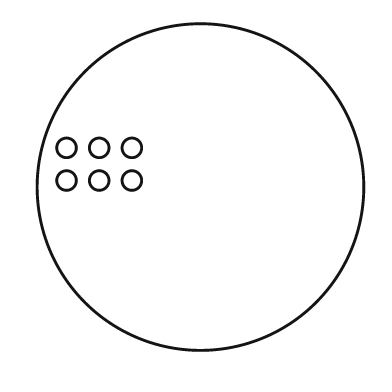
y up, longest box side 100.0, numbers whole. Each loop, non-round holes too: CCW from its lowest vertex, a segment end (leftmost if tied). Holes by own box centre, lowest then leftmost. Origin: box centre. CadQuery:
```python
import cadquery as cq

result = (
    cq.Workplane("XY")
    .moveTo(0.0, 0.0)
    .circle(50.0)
    .moveTo(-41.0, 2.0)
    .circle(3.0)
    .moveTo(-31.0, 2.0)
    .circle(3.0)
    .moveTo(-21.0, 2.0)
    .circle(3.0)
    .moveTo(-41.0, 12.0)
    .circle(3.0)
    .moveTo(-31.0, 12.0)
    .circle(3.0)
    .moveTo(-21.0, 12.0)
    .circle(3.0)
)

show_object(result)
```